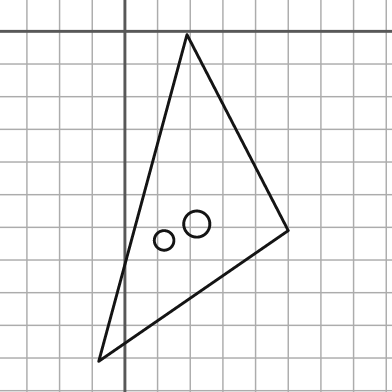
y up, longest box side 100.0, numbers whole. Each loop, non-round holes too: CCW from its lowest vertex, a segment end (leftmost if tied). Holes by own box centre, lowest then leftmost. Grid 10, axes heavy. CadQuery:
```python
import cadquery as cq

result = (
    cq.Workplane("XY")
    .moveTo(-8.0, -101.0)
    .lineTo(50.0, -61.0)
    .lineTo(19.0, -1.0)
    .close()
    .moveTo(12.0, -64.0)
    .circle(3.0)
    .moveTo(22.0, -59.0)
    .circle(4.0)
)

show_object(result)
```